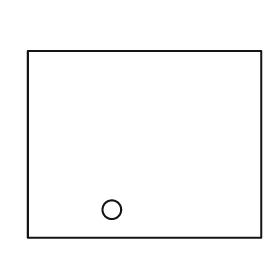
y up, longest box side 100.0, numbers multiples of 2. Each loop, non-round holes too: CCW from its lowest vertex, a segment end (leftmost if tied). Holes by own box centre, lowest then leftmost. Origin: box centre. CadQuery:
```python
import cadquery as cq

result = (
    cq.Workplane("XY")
    .moveTo(-50.0, -40.0)
    .lineTo(50.0, -40.0)
    .lineTo(50.0, 40.0)
    .lineTo(-50.0, 40.0)
    .close()
    .moveTo(-14.0, -28.0)
    .circle(4.0)
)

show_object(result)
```